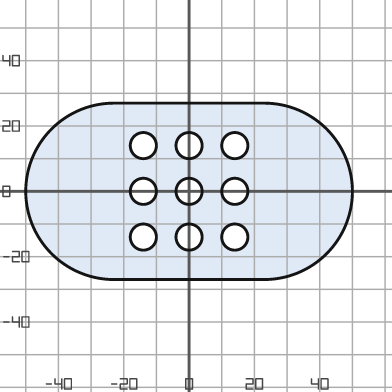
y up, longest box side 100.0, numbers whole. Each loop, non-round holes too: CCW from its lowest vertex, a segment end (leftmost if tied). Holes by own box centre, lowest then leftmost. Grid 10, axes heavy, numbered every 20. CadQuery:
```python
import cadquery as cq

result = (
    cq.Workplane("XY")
    .moveTo(-23.0, -27.0)
    .lineTo(23.0, -27.0)
    .threePointArc((50.0, 0.0), (23.0, 27.0))
    .lineTo(-23.0, 27.0)
    .threePointArc((-50.0, 0.0), (-23.0, -27.0))
    .close()
    .moveTo(-14.0, -14.0)
    .circle(4.0)
    .moveTo(0.0, -14.0)
    .circle(4.0)
    .moveTo(14.0, -14.0)
    .circle(4.0)
    .moveTo(-14.0, 0.0)
    .circle(4.0)
    .moveTo(0.0, 0.0)
    .circle(4.0)
    .moveTo(14.0, 0.0)
    .circle(4.0)
    .moveTo(-14.0, 14.0)
    .circle(4.0)
    .moveTo(0.0, 14.0)
    .circle(4.0)
    .moveTo(14.0, 14.0)
    .circle(4.0)
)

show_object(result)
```